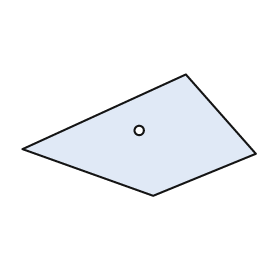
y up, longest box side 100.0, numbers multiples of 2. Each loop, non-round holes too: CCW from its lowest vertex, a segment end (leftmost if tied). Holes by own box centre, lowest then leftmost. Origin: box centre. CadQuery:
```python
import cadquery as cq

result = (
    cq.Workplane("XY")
    .moveTo(6.0, -26.0)
    .lineTo(50.0, -8.0)
    .lineTo(20.0, 26.0)
    .lineTo(-50.0, -6.0)
    .close()
    .moveTo(0.0, 2.0)
    .circle(2.0)
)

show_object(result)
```